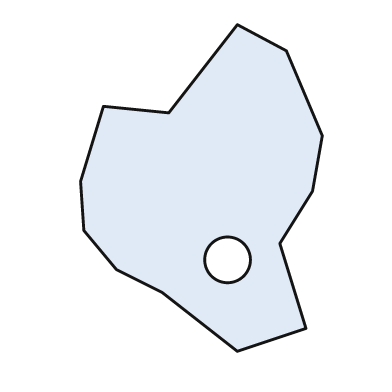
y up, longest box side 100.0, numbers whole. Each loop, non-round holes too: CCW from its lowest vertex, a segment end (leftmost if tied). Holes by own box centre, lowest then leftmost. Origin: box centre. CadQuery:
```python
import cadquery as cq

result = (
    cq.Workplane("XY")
    .moveTo(11.0, -50.0)
    .lineTo(32.0, -43.0)
    .lineTo(24.0, -17.0)
    .lineTo(34.0, -1.0)
    .lineTo(37.0, 16.0)
    .lineTo(26.0, 42.0)
    .lineTo(11.0, 50.0)
    .lineTo(-10.0, 23.0)
    .lineTo(-30.0, 25.0)
    .lineTo(-37.0, 2.0)
    .lineTo(-36.0, -13.0)
    .lineTo(-26.0, -25.0)
    .lineTo(-12.0, -32.0)
    .close()
    .moveTo(8.0, -22.0)
    .circle(7.0)
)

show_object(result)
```